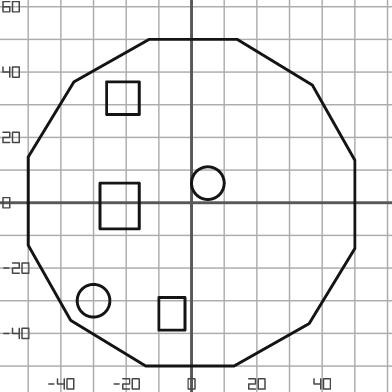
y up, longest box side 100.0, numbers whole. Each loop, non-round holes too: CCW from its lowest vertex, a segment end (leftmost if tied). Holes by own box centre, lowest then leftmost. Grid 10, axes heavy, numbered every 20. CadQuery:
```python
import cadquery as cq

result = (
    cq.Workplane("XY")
    .moveTo(-14.0, -50.0)
    .lineTo(13.0, -50.0)
    .lineTo(36.0, -37.0)
    .lineTo(50.0, -14.0)
    .lineTo(50.0, 13.0)
    .lineTo(37.0, 36.0)
    .lineTo(14.0, 50.0)
    .lineTo(-13.0, 50.0)
    .lineTo(-36.0, 37.0)
    .lineTo(-50.0, 14.0)
    .lineTo(-50.0, -13.0)
    .lineTo(-37.0, -36.0)
    .close()
    .moveTo(-10.0, -39.0)
    .lineTo(-2.0, -39.0)
    .lineTo(-2.0, -29.0)
    .lineTo(-10.0, -29.0)
    .close()
    .moveTo(-30.0, -30.0)
    .circle(5.0)
    .moveTo(-28.0, -8.0)
    .lineTo(-16.0, -8.0)
    .lineTo(-16.0, 6.0)
    .lineTo(-28.0, 6.0)
    .close()
    .moveTo(5.0, 6.0)
    .circle(5.0)
    .moveTo(-26.0, 27.0)
    .lineTo(-16.0, 27.0)
    .lineTo(-16.0, 37.0)
    .lineTo(-26.0, 37.0)
    .close()
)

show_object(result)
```